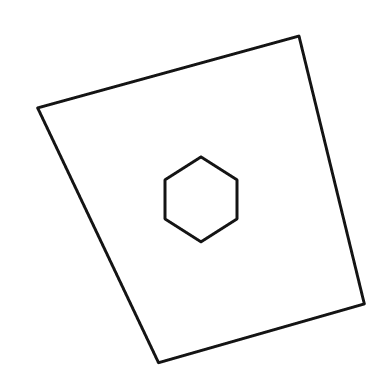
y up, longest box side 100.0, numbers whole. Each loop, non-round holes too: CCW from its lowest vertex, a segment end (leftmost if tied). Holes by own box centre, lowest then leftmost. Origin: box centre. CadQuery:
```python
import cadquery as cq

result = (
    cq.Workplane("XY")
    .moveTo(-13.0, -50.0)
    .lineTo(50.0, -32.0)
    .lineTo(30.0, 50.0)
    .lineTo(-50.0, 28.0)
    .close()
    .moveTo(0.0, -13.0)
    .lineTo(11.0, -6.0)
    .lineTo(11.0, 6.0)
    .lineTo(0.0, 13.0)
    .lineTo(-11.0, 6.0)
    .lineTo(-11.0, -6.0)
    .close()
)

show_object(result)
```